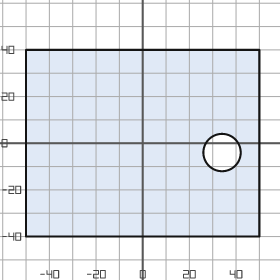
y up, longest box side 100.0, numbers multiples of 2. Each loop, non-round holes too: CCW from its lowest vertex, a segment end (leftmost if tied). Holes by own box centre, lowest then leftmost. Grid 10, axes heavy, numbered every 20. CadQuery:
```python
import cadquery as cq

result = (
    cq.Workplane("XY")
    .moveTo(-50.0, -40.0)
    .lineTo(50.0, -40.0)
    .lineTo(50.0, 40.0)
    .lineTo(-50.0, 40.0)
    .close()
    .moveTo(34.0, -4.0)
    .circle(8.0)
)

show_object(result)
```